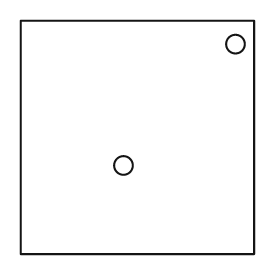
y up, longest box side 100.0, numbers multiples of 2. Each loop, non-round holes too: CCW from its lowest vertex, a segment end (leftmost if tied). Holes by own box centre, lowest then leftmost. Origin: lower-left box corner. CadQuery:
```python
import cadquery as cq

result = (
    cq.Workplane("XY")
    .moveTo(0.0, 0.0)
    .lineTo(100.0, 0.0)
    .lineTo(100.0, 100.0)
    .lineTo(0.0, 100.0)
    .close()
    .moveTo(44.0, 38.0)
    .circle(4.0)
    .moveTo(92.0, 90.0)
    .circle(4.0)
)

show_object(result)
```